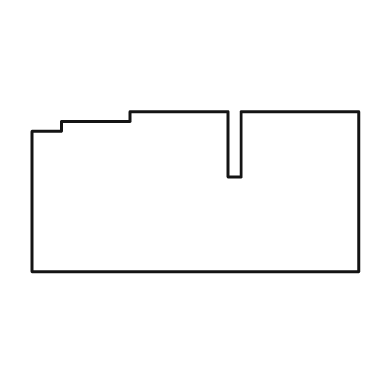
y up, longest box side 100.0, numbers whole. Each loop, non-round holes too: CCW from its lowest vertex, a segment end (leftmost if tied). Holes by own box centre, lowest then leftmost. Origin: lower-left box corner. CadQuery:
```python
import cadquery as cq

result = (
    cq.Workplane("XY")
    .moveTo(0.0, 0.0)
    .lineTo(100.0, 0.0)
    .lineTo(100.0, 49.0)
    .lineTo(64.0, 49.0)
    .lineTo(64.0, 29.0)
    .lineTo(60.0, 29.0)
    .lineTo(60.0, 49.0)
    .lineTo(30.0, 49.0)
    .lineTo(30.0, 46.0)
    .lineTo(9.0, 46.0)
    .lineTo(9.0, 43.0)
    .lineTo(0.0, 43.0)
    .close()
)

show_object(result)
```